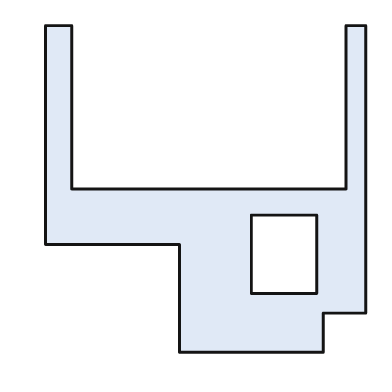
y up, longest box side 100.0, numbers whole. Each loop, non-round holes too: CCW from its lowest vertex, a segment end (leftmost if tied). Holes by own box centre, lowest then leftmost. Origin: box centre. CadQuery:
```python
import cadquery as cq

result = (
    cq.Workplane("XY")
    .moveTo(-8.0, -50.0)
    .lineTo(36.0, -50.0)
    .lineTo(36.0, -38.0)
    .lineTo(49.0, -38.0)
    .lineTo(49.0, 50.0)
    .lineTo(43.0, 50.0)
    .lineTo(43.0, 0.0)
    .lineTo(-41.0, 0.0)
    .lineTo(-41.0, 50.0)
    .lineTo(-49.0, 50.0)
    .lineTo(-49.0, -17.0)
    .lineTo(-8.0, -17.0)
    .close()
    .moveTo(14.0, -32.0)
    .lineTo(34.0, -32.0)
    .lineTo(34.0, -8.0)
    .lineTo(14.0, -8.0)
    .close()
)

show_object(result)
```